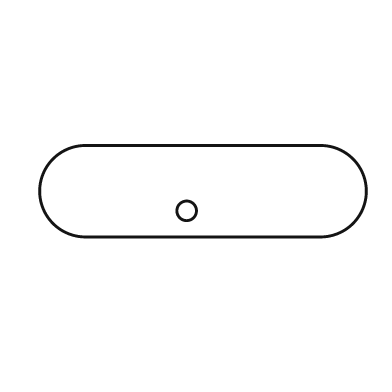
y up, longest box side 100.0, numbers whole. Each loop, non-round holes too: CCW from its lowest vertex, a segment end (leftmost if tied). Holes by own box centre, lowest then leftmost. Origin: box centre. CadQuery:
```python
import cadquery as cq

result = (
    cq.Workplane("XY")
    .moveTo(-36.0, -14.0)
    .lineTo(36.0, -14.0)
    .threePointArc((50.0, 0.0), (36.0, 14.0))
    .lineTo(-36.0, 14.0)
    .threePointArc((-50.0, 0.0), (-36.0, -14.0))
    .close()
    .moveTo(-5.0, -6.0)
    .circle(3.0)
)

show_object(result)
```